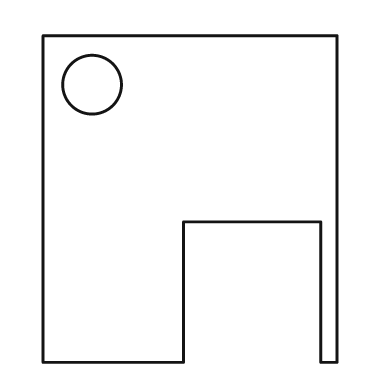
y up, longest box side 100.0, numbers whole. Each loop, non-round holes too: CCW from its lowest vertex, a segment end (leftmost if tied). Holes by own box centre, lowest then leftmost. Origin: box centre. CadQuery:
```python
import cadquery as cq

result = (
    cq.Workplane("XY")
    .moveTo(-45.0, -50.0)
    .lineTo(-2.0, -50.0)
    .lineTo(-2.0, -7.0)
    .lineTo(40.0, -7.0)
    .lineTo(40.0, -50.0)
    .lineTo(45.0, -50.0)
    .lineTo(45.0, 50.0)
    .lineTo(-45.0, 50.0)
    .close()
    .moveTo(-30.0, 35.0)
    .circle(9.0)
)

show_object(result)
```